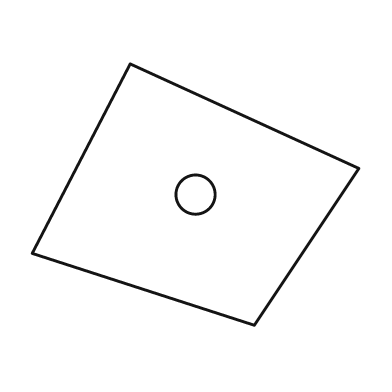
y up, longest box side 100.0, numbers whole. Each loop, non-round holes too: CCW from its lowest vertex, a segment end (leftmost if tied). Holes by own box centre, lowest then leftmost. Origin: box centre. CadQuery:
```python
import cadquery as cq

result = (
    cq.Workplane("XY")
    .moveTo(18.0, -40.0)
    .lineTo(50.0, 8.0)
    .lineTo(-20.0, 40.0)
    .lineTo(-50.0, -18.0)
    .close()
    .moveTo(0.0, 0.0)
    .circle(6.0)
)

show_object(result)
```